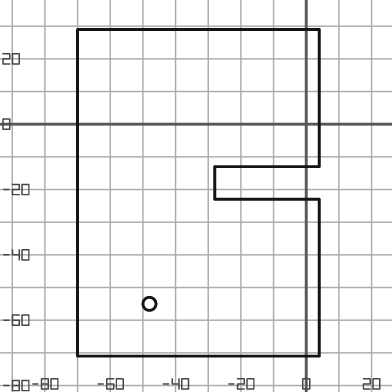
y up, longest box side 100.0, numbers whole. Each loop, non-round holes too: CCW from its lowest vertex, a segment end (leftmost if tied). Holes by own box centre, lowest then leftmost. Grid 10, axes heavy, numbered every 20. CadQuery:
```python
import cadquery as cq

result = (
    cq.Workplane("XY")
    .moveTo(-70.0, -71.0)
    .lineTo(4.0, -71.0)
    .lineTo(4.0, -23.0)
    .lineTo(-28.0, -23.0)
    .lineTo(-28.0, -13.0)
    .lineTo(4.0, -13.0)
    .lineTo(4.0, 29.0)
    .lineTo(-70.0, 29.0)
    .close()
    .moveTo(-48.0, -55.0)
    .circle(2.0)
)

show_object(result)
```